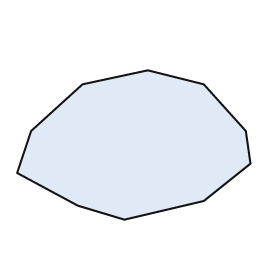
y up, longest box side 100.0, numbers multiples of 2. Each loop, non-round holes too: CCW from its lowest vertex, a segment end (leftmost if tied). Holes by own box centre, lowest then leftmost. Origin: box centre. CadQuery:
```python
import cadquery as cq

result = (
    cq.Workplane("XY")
    .moveTo(-4.0, -32.0)
    .lineTo(30.0, -24.0)
    .lineTo(50.0, -8.0)
    .lineTo(48.0, 6.0)
    .lineTo(30.0, 26.0)
    .lineTo(6.0, 32.0)
    .lineTo(-22.0, 26.0)
    .lineTo(-44.0, 6.0)
    .lineTo(-50.0, -12.0)
    .lineTo(-24.0, -26.0)
    .close()
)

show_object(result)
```